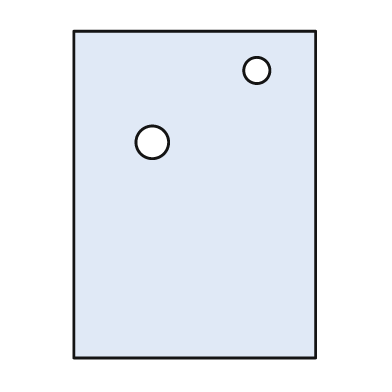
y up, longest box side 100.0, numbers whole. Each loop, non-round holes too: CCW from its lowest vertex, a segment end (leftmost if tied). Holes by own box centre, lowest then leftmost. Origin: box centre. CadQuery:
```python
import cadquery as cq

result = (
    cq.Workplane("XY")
    .moveTo(-37.0, -50.0)
    .lineTo(37.0, -50.0)
    .lineTo(37.0, 50.0)
    .lineTo(-37.0, 50.0)
    .close()
    .moveTo(-13.0, 16.0)
    .circle(5.0)
    .moveTo(19.0, 38.0)
    .circle(4.0)
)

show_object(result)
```